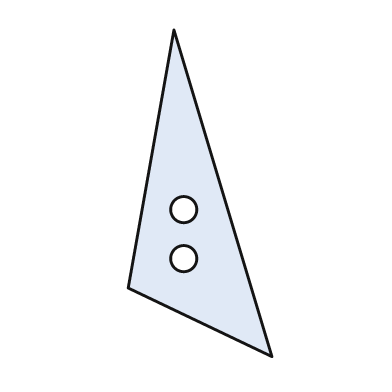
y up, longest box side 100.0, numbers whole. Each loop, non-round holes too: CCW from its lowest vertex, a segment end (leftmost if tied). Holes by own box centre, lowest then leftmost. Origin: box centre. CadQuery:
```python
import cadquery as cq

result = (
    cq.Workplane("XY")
    .moveTo(22.0, -50.0)
    .lineTo(-8.0, 50.0)
    .lineTo(-22.0, -29.0)
    .close()
    .moveTo(-5.0, -20.0)
    .circle(4.0)
    .moveTo(-5.0, -5.0)
    .circle(4.0)
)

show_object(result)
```